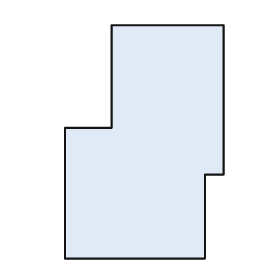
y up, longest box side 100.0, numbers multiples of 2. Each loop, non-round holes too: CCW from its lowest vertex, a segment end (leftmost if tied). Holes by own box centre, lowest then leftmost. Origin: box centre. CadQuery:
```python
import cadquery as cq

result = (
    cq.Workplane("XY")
    .moveTo(-34.0, -50.0)
    .lineTo(26.0, -50.0)
    .lineTo(26.0, -14.0)
    .lineTo(34.0, -14.0)
    .lineTo(34.0, 50.0)
    .lineTo(-14.0, 50.0)
    .lineTo(-14.0, 6.0)
    .lineTo(-34.0, 6.0)
    .close()
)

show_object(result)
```